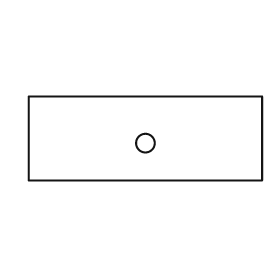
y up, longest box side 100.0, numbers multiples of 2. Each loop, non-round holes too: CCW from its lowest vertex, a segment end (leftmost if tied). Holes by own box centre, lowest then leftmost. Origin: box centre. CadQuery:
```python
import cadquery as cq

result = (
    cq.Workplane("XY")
    .moveTo(-50.0, -18.0)
    .lineTo(50.0, -18.0)
    .lineTo(50.0, 18.0)
    .lineTo(-50.0, 18.0)
    .close()
    .moveTo(0.0, -2.0)
    .circle(4.0)
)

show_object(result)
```